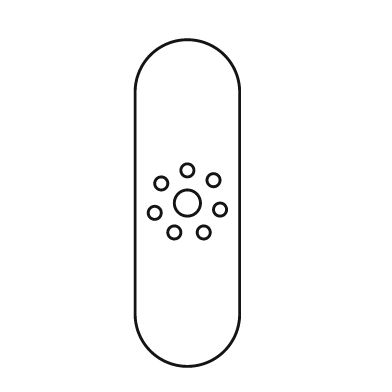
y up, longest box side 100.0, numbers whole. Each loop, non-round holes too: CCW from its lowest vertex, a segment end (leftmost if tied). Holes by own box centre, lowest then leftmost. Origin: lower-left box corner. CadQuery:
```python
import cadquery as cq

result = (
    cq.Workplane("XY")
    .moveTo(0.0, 16.0)
    .threePointArc((16.0, 0.0), (32.0, 16.0))
    .lineTo(32.0, 84.0)
    .threePointArc((16.0, 100.0), (0.0, 84.0))
    .close()
    .moveTo(12.0, 41.0)
    .circle(2.0)
    .moveTo(21.0, 41.0)
    .circle(2.0)
    .moveTo(6.0, 47.0)
    .circle(2.0)
    .moveTo(26.0, 48.0)
    .circle(2.0)
    .moveTo(16.0, 50.0)
    .circle(4.0)
    .moveTo(8.0, 56.0)
    .circle(2.0)
    .moveTo(24.0, 57.0)
    .circle(2.0)
    .moveTo(16.0, 60.0)
    .circle(2.0)
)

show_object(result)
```